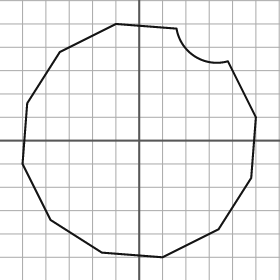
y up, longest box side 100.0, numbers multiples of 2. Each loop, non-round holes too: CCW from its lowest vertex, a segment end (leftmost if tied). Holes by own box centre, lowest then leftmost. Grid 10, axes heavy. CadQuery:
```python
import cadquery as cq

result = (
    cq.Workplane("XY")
    .moveTo(10.0, -50.0)
    .lineTo(34.0, -38.0)
    .lineTo(48.0, -16.0)
    .lineTo(50.0, 10.0)
    .lineTo(38.0, 34.0)
    .threePointArc((24.0, 36.0), (16.0, 48.0))
    .lineTo(-10.0, 50.0)
    .lineTo(-34.0, 38.0)
    .lineTo(-48.0, 16.0)
    .lineTo(-50.0, -10.0)
    .lineTo(-38.0, -34.0)
    .lineTo(-16.0, -48.0)
    .close()
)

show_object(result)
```